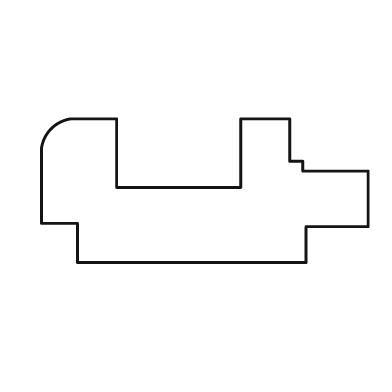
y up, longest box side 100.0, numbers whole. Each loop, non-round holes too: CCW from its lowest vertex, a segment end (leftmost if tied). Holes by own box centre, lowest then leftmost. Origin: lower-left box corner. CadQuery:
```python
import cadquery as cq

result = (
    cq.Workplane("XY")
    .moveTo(11.0, 0.0)
    .lineTo(81.0, 0.0)
    .lineTo(81.0, 11.0)
    .lineTo(100.0, 11.0)
    .lineTo(100.0, 28.0)
    .lineTo(80.0, 28.0)
    .lineTo(80.0, 31.0)
    .lineTo(76.0, 31.0)
    .lineTo(76.0, 44.0)
    .lineTo(61.0, 44.0)
    .lineTo(61.0, 23.0)
    .lineTo(23.0, 23.0)
    .lineTo(23.0, 44.0)
    .lineTo(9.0, 44.0)
    .threePointArc((3.0, 41.0), (0.0, 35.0))
    .lineTo(0.0, 12.0)
    .lineTo(11.0, 12.0)
    .close()
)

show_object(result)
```